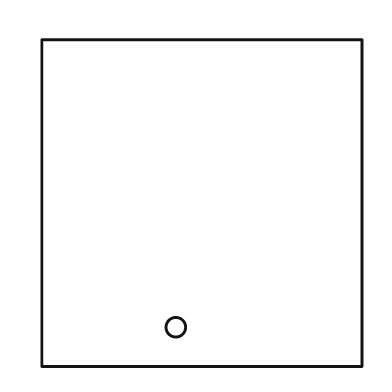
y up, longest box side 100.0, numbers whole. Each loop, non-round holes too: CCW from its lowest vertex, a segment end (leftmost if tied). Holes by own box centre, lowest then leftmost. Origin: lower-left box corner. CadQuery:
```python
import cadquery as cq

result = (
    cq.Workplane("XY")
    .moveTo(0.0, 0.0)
    .lineTo(98.0, 0.0)
    .lineTo(98.0, 100.0)
    .lineTo(0.0, 100.0)
    .close()
    .moveTo(41.0, 12.0)
    .circle(3.0)
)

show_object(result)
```